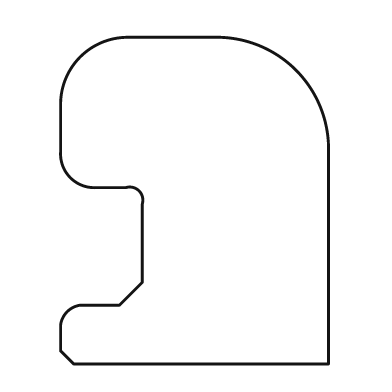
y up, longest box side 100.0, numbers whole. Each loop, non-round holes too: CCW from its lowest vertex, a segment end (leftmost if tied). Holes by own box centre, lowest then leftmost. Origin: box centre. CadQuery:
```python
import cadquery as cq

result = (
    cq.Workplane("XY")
    .moveTo(-37.0, -50.0)
    .lineTo(41.0, -50.0)
    .lineTo(41.0, 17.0)
    .threePointArc((31.0, 40.0), (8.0, 50.0))
    .lineTo(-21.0, 50.0)
    .threePointArc((-35.0, 44.0), (-41.0, 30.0))
    .lineTo(-41.0, 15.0)
    .threePointArc((-38.0, 7.0), (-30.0, 4.0))
    .lineTo(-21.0, 4.0)
    .threePointArc((-17.0, 3.0), (-16.0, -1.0))
    .lineTo(-16.0, -25.0)
    .lineTo(-23.0, -32.0)
    .lineTo(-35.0, -32.0)
    .threePointArc((-39.0, -34.0), (-41.0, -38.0))
    .lineTo(-41.0, -46.0)
    .close()
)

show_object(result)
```